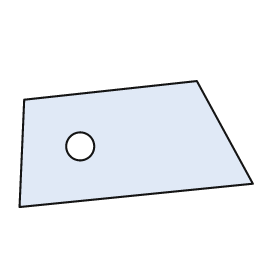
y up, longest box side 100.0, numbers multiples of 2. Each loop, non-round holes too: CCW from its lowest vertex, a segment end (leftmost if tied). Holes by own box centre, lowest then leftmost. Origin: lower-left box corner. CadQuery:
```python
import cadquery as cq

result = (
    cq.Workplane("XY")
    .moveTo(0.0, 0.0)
    .lineTo(100.0, 10.0)
    .lineTo(76.0, 54.0)
    .lineTo(2.0, 46.0)
    .close()
    .moveTo(26.0, 26.0)
    .circle(6.0)
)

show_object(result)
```